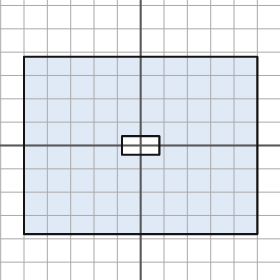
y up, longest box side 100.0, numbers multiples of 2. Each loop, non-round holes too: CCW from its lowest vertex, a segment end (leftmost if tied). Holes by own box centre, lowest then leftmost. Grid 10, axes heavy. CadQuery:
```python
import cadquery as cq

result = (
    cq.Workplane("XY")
    .moveTo(-50.0, -38.0)
    .lineTo(50.0, -38.0)
    .lineTo(50.0, 38.0)
    .lineTo(-50.0, 38.0)
    .close()
    .moveTo(-8.0, -4.0)
    .lineTo(8.0, -4.0)
    .lineTo(8.0, 4.0)
    .lineTo(-8.0, 4.0)
    .close()
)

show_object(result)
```